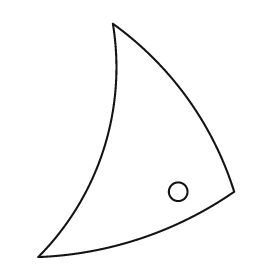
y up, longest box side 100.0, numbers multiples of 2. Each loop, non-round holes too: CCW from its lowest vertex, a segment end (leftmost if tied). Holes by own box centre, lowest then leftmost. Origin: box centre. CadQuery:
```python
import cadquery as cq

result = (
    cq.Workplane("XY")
    .moveTo(-42.0, -50.0)
    .threePointArc((2.0, -42.0), (42.0, -22.0))
    .threePointArc((22.0, 18.0), (-10.0, 50.0))
    .threePointArc((-14.0, -4.0), (-42.0, -50.0))
    .close()
    .moveTo(18.0, -22.0)
    .circle(4.0)
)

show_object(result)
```